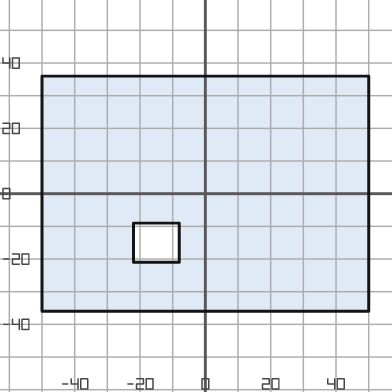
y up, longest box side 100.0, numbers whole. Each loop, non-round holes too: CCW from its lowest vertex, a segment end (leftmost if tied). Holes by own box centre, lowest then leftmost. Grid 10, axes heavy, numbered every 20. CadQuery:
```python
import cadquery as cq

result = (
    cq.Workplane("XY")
    .moveTo(-50.0, -36.0)
    .lineTo(50.0, -36.0)
    .lineTo(50.0, 36.0)
    .lineTo(-50.0, 36.0)
    .close()
    .moveTo(-22.0, -21.0)
    .lineTo(-8.0, -21.0)
    .lineTo(-8.0, -9.0)
    .lineTo(-22.0, -9.0)
    .close()
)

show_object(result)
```